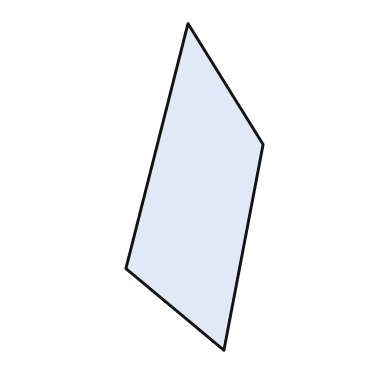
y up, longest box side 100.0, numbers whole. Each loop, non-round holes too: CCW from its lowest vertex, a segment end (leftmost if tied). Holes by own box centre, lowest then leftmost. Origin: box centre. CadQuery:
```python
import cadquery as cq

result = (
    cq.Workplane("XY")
    .moveTo(9.0, -50.0)
    .lineTo(21.0, 13.0)
    .lineTo(-2.0, 50.0)
    .lineTo(-21.0, -25.0)
    .close()
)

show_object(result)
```